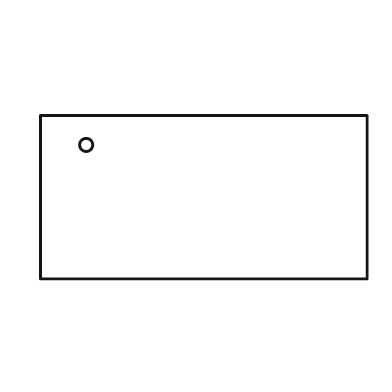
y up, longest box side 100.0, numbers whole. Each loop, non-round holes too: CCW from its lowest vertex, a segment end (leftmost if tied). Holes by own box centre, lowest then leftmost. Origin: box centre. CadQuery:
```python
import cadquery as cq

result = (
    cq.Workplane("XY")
    .moveTo(-50.0, -25.0)
    .lineTo(50.0, -25.0)
    .lineTo(50.0, 25.0)
    .lineTo(-50.0, 25.0)
    .close()
    .moveTo(-36.0, 16.0)
    .circle(2.0)
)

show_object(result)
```